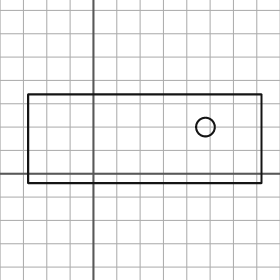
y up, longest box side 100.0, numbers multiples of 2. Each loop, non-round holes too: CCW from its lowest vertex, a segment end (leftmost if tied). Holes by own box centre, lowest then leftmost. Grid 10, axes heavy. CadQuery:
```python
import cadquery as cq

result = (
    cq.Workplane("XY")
    .moveTo(-28.0, -4.0)
    .lineTo(72.0, -4.0)
    .lineTo(72.0, 34.0)
    .lineTo(-28.0, 34.0)
    .close()
    .moveTo(48.0, 20.0)
    .circle(4.0)
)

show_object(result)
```